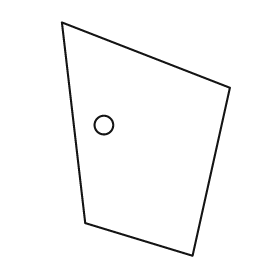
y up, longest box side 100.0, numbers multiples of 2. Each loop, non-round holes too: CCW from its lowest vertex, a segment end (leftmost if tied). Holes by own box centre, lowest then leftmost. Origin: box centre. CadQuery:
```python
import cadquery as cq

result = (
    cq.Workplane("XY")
    .moveTo(20.0, -50.0)
    .lineTo(36.0, 22.0)
    .lineTo(-36.0, 50.0)
    .lineTo(-26.0, -36.0)
    .close()
    .moveTo(-18.0, 6.0)
    .circle(4.0)
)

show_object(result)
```